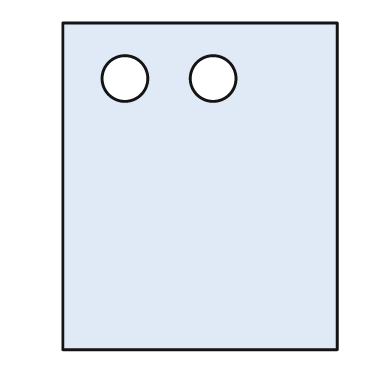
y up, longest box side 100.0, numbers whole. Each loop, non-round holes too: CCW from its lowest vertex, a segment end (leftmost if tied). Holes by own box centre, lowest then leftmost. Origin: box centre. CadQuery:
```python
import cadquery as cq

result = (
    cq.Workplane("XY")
    .moveTo(-42.0, -50.0)
    .lineTo(42.0, -50.0)
    .lineTo(42.0, 50.0)
    .lineTo(-42.0, 50.0)
    .close()
    .moveTo(-23.0, 33.0)
    .circle(7.0)
    .moveTo(4.0, 33.0)
    .circle(7.0)
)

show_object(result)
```